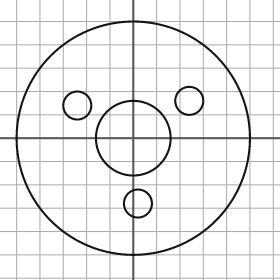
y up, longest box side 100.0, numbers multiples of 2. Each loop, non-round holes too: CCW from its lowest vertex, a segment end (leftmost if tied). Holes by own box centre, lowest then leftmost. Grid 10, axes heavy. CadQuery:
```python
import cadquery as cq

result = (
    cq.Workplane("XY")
    .moveTo(0.0, 0.0)
    .circle(50.0)
    .moveTo(2.0, -28.0)
    .circle(6.0)
    .moveTo(0.0, 0.0)
    .circle(16.0)
    .moveTo(-24.0, 14.0)
    .circle(6.0)
    .moveTo(24.0, 16.0)
    .circle(6.0)
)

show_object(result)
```